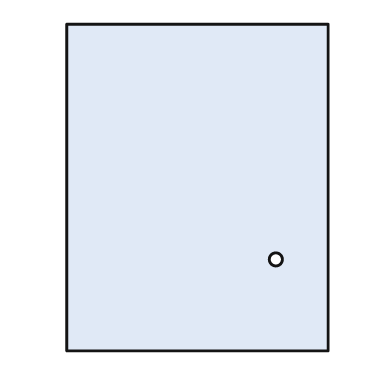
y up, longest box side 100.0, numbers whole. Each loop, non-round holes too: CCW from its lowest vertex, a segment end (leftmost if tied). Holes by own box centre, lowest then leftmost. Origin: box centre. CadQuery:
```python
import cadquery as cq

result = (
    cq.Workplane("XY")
    .moveTo(-40.0, -50.0)
    .lineTo(40.0, -50.0)
    .lineTo(40.0, 50.0)
    .lineTo(-40.0, 50.0)
    .close()
    .moveTo(24.0, -22.0)
    .circle(2.0)
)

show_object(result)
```